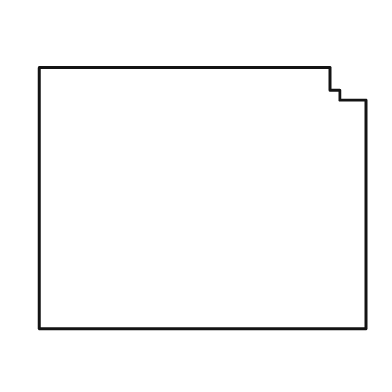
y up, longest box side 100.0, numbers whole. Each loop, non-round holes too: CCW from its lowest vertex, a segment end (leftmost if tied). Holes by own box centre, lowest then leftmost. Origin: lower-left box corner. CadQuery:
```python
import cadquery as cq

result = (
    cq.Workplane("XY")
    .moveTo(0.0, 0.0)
    .lineTo(100.0, 0.0)
    .lineTo(100.0, 70.0)
    .lineTo(92.0, 70.0)
    .lineTo(92.0, 73.0)
    .lineTo(89.0, 73.0)
    .lineTo(89.0, 80.0)
    .lineTo(0.0, 80.0)
    .close()
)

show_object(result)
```